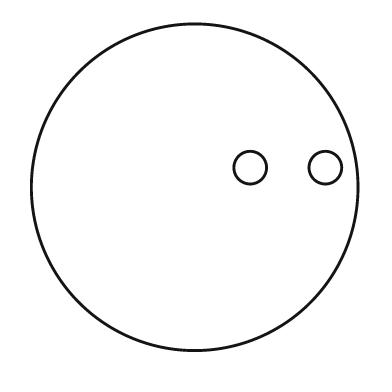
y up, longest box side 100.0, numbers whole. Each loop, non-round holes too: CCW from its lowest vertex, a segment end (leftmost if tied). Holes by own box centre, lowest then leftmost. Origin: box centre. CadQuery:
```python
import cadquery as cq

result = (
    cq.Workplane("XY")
    .moveTo(0.0, 0.0)
    .circle(50.0)
    .moveTo(17.0, 6.0)
    .circle(5.0)
    .moveTo(40.0, 6.0)
    .circle(5.0)
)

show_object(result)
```